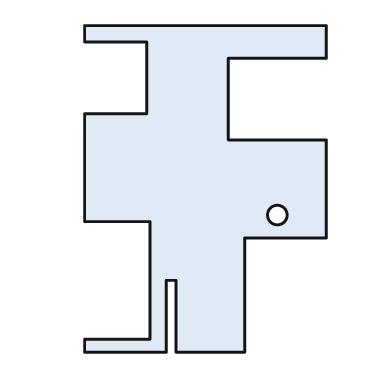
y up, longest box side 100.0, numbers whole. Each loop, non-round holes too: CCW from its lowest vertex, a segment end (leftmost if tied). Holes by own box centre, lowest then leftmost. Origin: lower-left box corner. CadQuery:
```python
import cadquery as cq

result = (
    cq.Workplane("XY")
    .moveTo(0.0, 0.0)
    .lineTo(25.0, 0.0)
    .lineTo(25.0, 22.0)
    .lineTo(28.0, 22.0)
    .lineTo(28.0, 0.0)
    .lineTo(49.0, 0.0)
    .lineTo(49.0, 35.0)
    .lineTo(74.0, 35.0)
    .lineTo(74.0, 65.0)
    .lineTo(44.0, 65.0)
    .lineTo(44.0, 90.0)
    .lineTo(74.0, 90.0)
    .lineTo(74.0, 100.0)
    .lineTo(0.0, 100.0)
    .lineTo(0.0, 95.0)
    .lineTo(19.0, 95.0)
    .lineTo(19.0, 73.0)
    .lineTo(0.0, 73.0)
    .lineTo(0.0, 40.0)
    .lineTo(20.0, 40.0)
    .lineTo(20.0, 4.0)
    .lineTo(0.0, 4.0)
    .close()
    .moveTo(59.0, 42.0)
    .circle(3.0)
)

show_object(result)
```